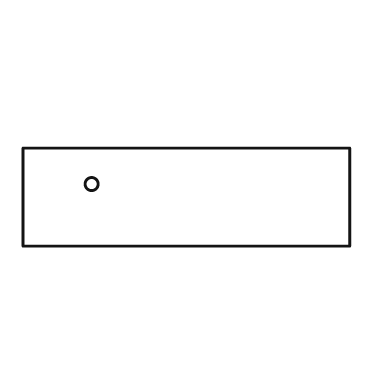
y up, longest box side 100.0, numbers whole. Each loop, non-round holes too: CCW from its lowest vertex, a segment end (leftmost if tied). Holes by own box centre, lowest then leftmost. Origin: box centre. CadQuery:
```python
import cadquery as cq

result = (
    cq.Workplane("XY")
    .moveTo(-50.0, -15.0)
    .lineTo(50.0, -15.0)
    .lineTo(50.0, 15.0)
    .lineTo(-50.0, 15.0)
    .close()
    .moveTo(-29.0, 4.0)
    .circle(2.0)
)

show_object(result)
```